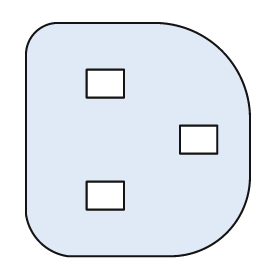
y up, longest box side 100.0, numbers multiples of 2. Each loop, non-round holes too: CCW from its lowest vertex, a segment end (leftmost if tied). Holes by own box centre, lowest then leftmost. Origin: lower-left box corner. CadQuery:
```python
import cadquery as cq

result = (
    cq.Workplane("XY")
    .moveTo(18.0, 0.0)
    .lineTo(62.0, 0.0)
    .threePointArc((86.0, 10.0), (96.0, 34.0))
    .lineTo(96.0, 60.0)
    .threePointArc((84.0, 88.0), (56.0, 100.0))
    .lineTo(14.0, 100.0)
    .threePointArc((4.0, 96.0), (0.0, 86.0))
    .lineTo(0.0, 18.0)
    .threePointArc((6.0, 6.0), (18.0, 0.0))
    .close()
    .moveTo(26.0, 20.0)
    .lineTo(42.0, 20.0)
    .lineTo(42.0, 32.0)
    .lineTo(26.0, 32.0)
    .close()
    .moveTo(66.0, 44.0)
    .lineTo(82.0, 44.0)
    .lineTo(82.0, 56.0)
    .lineTo(66.0, 56.0)
    .close()
    .moveTo(26.0, 68.0)
    .lineTo(42.0, 68.0)
    .lineTo(42.0, 80.0)
    .lineTo(26.0, 80.0)
    .close()
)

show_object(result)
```